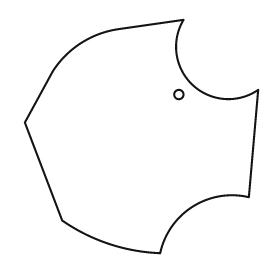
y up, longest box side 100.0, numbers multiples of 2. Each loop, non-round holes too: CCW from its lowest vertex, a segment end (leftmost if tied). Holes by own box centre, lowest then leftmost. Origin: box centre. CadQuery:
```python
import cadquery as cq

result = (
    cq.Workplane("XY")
    .moveTo(8.0, -50.0)
    .threePointArc((22.0, -30.0), (46.0, -26.0))
    .lineTo(50.0, 20.0)
    .threePointArc((22.0, 22.0), (18.0, 50.0))
    .lineTo(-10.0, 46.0)
    .threePointArc((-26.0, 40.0), (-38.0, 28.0))
    .lineTo(-50.0, 6.0)
    .lineTo(-34.0, -36.0)
    .threePointArc((-14.0, -46.0), (8.0, -50.0))
    .close()
    .moveTo(16.0, 18.0)
    .circle(2.0)
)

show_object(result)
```